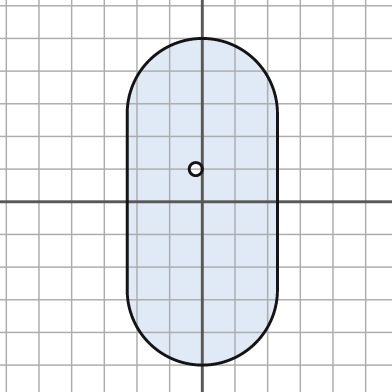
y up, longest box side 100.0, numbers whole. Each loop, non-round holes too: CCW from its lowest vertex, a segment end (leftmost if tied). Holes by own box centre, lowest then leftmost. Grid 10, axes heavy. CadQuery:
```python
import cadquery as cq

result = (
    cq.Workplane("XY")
    .moveTo(-23.0, -27.0)
    .threePointArc((0.0, -50.0), (23.0, -27.0))
    .lineTo(23.0, 27.0)
    .threePointArc((0.0, 50.0), (-23.0, 27.0))
    .close()
    .moveTo(-2.0, 10.0)
    .circle(2.0)
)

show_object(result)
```